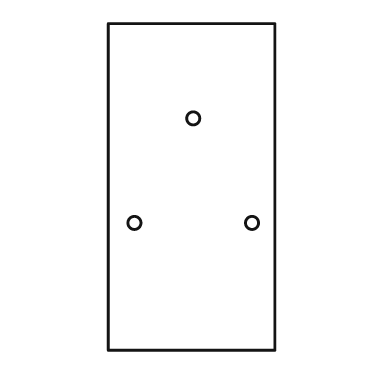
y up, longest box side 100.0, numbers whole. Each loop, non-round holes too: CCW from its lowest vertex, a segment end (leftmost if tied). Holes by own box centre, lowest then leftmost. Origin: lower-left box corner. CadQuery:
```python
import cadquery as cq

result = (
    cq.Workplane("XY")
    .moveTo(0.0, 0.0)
    .lineTo(51.0, 0.0)
    .lineTo(51.0, 100.0)
    .lineTo(0.0, 100.0)
    .close()
    .moveTo(8.0, 39.0)
    .circle(2.0)
    .moveTo(44.0, 39.0)
    .circle(2.0)
    .moveTo(26.0, 71.0)
    .circle(2.0)
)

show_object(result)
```